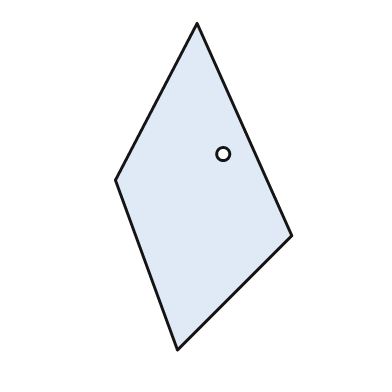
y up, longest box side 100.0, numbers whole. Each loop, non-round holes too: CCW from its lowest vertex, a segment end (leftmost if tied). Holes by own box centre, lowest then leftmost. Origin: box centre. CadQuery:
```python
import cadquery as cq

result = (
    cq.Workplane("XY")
    .moveTo(-8.0, -50.0)
    .lineTo(27.0, -15.0)
    .lineTo(-2.0, 50.0)
    .lineTo(-27.0, 2.0)
    .close()
    .moveTo(6.0, 10.0)
    .circle(2.0)
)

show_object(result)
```